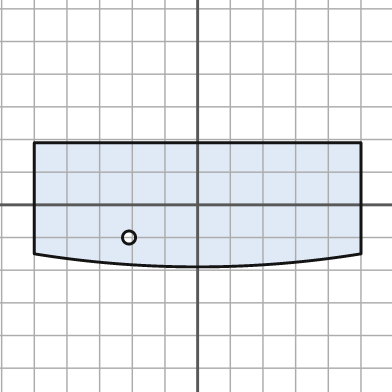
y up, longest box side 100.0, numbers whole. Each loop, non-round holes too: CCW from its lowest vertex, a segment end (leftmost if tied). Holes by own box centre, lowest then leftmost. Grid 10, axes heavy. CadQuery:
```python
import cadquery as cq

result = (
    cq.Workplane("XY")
    .moveTo(-50.0, -15.0)
    .threePointArc((0.0, -19.0), (50.0, -15.0))
    .lineTo(50.0, 19.0)
    .lineTo(-50.0, 19.0)
    .close()
    .moveTo(-21.0, -10.0)
    .circle(2.0)
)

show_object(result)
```